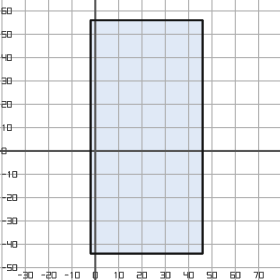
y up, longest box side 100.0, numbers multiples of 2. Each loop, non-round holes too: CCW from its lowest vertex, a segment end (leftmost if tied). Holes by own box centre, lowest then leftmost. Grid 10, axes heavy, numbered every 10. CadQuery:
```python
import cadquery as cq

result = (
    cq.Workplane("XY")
    .moveTo(-2.0, -44.0)
    .lineTo(46.0, -44.0)
    .lineTo(46.0, 56.0)
    .lineTo(-2.0, 56.0)
    .close()
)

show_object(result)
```